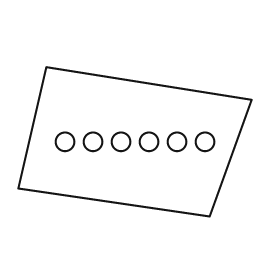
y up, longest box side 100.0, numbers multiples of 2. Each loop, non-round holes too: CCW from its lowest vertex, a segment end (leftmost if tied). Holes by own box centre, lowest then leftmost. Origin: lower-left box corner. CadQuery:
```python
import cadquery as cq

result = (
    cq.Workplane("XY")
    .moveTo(82.0, 0.0)
    .lineTo(100.0, 50.0)
    .lineTo(12.0, 64.0)
    .lineTo(0.0, 12.0)
    .close()
    .moveTo(20.0, 32.0)
    .circle(4.0)
    .moveTo(32.0, 32.0)
    .circle(4.0)
    .moveTo(44.0, 32.0)
    .circle(4.0)
    .moveTo(56.0, 32.0)
    .circle(4.0)
    .moveTo(68.0, 32.0)
    .circle(4.0)
    .moveTo(80.0, 32.0)
    .circle(4.0)
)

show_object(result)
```